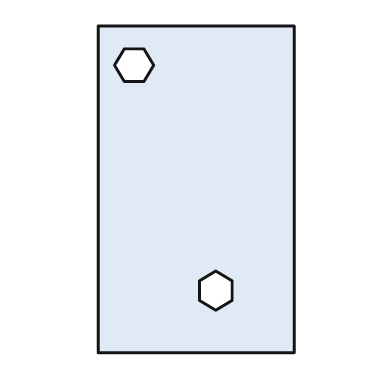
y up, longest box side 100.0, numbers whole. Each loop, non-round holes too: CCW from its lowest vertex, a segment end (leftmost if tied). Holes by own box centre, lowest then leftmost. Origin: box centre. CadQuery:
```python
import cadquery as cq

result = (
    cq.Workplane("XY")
    .moveTo(-30.0, -50.0)
    .lineTo(30.0, -50.0)
    .lineTo(30.0, 50.0)
    .lineTo(-30.0, 50.0)
    .close()
    .moveTo(6.0, -37.0)
    .lineTo(11.0, -34.0)
    .lineTo(11.0, -28.0)
    .lineTo(6.0, -25.0)
    .lineTo(1.0, -28.0)
    .lineTo(1.0, -34.0)
    .close()
    .moveTo(-22.0, 33.0)
    .lineTo(-16.0, 33.0)
    .lineTo(-13.0, 38.0)
    .lineTo(-16.0, 43.0)
    .lineTo(-22.0, 43.0)
    .lineTo(-25.0, 38.0)
    .close()
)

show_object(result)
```